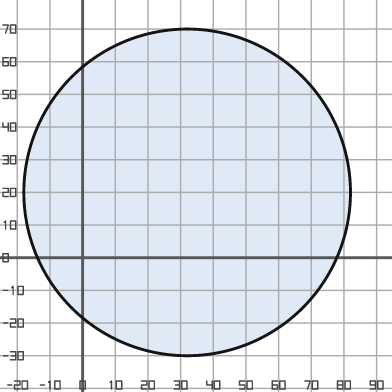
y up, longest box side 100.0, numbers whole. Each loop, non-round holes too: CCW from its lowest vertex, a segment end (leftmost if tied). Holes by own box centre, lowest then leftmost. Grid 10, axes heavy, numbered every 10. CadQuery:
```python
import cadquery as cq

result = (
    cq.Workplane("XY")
    .moveTo(32.0, 20.0)
    .circle(50.0)
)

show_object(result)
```